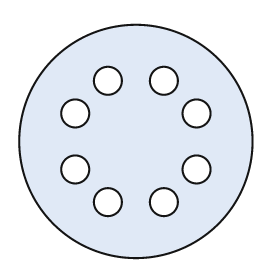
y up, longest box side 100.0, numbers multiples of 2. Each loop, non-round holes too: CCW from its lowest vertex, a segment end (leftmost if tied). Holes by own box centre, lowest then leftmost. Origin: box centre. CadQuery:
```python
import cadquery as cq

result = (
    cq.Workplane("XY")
    .moveTo(0.0, 0.0)
    .circle(50.0)
    .moveTo(-12.0, -26.0)
    .circle(6.0)
    .moveTo(12.0, -26.0)
    .circle(6.0)
    .moveTo(-26.0, -12.0)
    .circle(6.0)
    .moveTo(26.0, -12.0)
    .circle(6.0)
    .moveTo(-26.0, 12.0)
    .circle(6.0)
    .moveTo(26.0, 12.0)
    .circle(6.0)
    .moveTo(-12.0, 26.0)
    .circle(6.0)
    .moveTo(12.0, 26.0)
    .circle(6.0)
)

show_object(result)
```